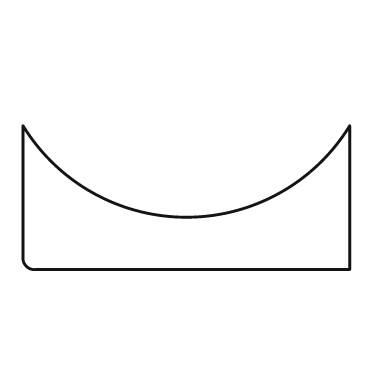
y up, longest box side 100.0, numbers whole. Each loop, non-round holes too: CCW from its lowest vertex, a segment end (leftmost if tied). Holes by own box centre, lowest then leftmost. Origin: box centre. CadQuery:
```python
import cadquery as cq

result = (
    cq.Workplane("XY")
    .moveTo(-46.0, -22.0)
    .lineTo(50.0, -22.0)
    .lineTo(50.0, 22.0)
    .threePointArc((0.0, -6.0), (-50.0, 22.0))
    .lineTo(-50.0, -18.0)
    .threePointArc((-49.0, -21.0), (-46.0, -22.0))
    .close()
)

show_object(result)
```